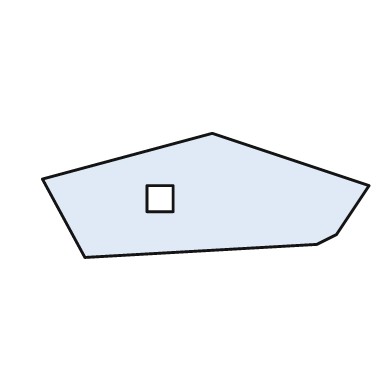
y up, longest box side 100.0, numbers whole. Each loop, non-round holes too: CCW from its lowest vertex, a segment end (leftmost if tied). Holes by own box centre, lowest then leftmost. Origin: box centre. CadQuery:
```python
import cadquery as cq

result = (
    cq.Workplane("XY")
    .moveTo(-37.0, -19.0)
    .lineTo(34.0, -15.0)
    .lineTo(40.0, -12.0)
    .lineTo(50.0, 3.0)
    .lineTo(2.0, 19.0)
    .lineTo(-50.0, 5.0)
    .close()
    .moveTo(-18.0, -5.0)
    .lineTo(-10.0, -5.0)
    .lineTo(-10.0, 3.0)
    .lineTo(-18.0, 3.0)
    .close()
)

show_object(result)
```